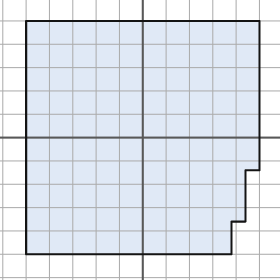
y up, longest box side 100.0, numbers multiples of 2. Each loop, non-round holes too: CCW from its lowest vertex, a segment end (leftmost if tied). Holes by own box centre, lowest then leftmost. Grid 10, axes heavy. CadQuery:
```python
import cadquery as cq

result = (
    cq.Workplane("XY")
    .moveTo(-50.0, -50.0)
    .lineTo(38.0, -50.0)
    .lineTo(38.0, -36.0)
    .lineTo(44.0, -36.0)
    .lineTo(44.0, -14.0)
    .lineTo(50.0, -14.0)
    .lineTo(50.0, 50.0)
    .lineTo(-50.0, 50.0)
    .close()
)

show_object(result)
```